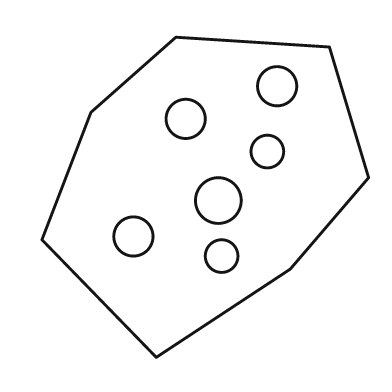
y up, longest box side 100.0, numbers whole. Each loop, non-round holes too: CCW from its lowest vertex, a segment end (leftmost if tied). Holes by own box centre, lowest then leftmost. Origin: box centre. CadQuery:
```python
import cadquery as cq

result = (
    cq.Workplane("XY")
    .moveTo(-15.0, -49.0)
    .lineTo(26.0, -22.0)
    .lineTo(50.0, 6.0)
    .lineTo(38.0, 46.0)
    .lineTo(-9.0, 49.0)
    .lineTo(-35.0, 26.0)
    .lineTo(-50.0, -13.0)
    .close()
    .moveTo(5.0, -18.0)
    .circle(5.0)
    .moveTo(-22.0, -12.0)
    .circle(6.0)
    .moveTo(4.0, -1.0)
    .circle(7.0)
    .moveTo(19.0, 14.0)
    .circle(5.0)
    .moveTo(-6.0, 24.0)
    .circle(6.0)
    .moveTo(22.0, 34.0)
    .circle(6.0)
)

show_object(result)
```